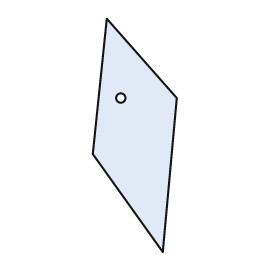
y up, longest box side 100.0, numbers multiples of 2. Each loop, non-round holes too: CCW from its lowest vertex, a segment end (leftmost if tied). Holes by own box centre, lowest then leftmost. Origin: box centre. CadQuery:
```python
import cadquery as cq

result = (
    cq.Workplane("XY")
    .moveTo(12.0, -50.0)
    .lineTo(18.0, 16.0)
    .lineTo(-12.0, 50.0)
    .lineTo(-18.0, -8.0)
    .close()
    .moveTo(-6.0, 16.0)
    .circle(2.0)
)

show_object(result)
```